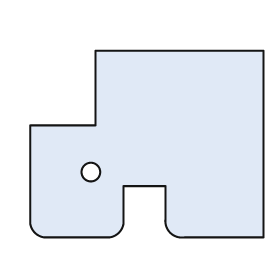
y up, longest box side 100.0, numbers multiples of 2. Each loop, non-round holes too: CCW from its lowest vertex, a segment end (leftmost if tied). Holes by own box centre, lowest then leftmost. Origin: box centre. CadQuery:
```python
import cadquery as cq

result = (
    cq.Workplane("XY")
    .moveTo(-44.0, -40.0)
    .lineTo(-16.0, -40.0)
    .threePointArc((-12.0, -38.0), (-10.0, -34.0))
    .lineTo(-10.0, -18.0)
    .lineTo(8.0, -18.0)
    .lineTo(8.0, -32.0)
    .threePointArc((10.0, -38.0), (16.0, -40.0))
    .lineTo(50.0, -40.0)
    .lineTo(50.0, 40.0)
    .lineTo(-22.0, 40.0)
    .lineTo(-22.0, 8.0)
    .lineTo(-50.0, 8.0)
    .lineTo(-50.0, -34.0)
    .threePointArc((-48.0, -38.0), (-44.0, -40.0))
    .close()
    .moveTo(-24.0, -12.0)
    .circle(4.0)
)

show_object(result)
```